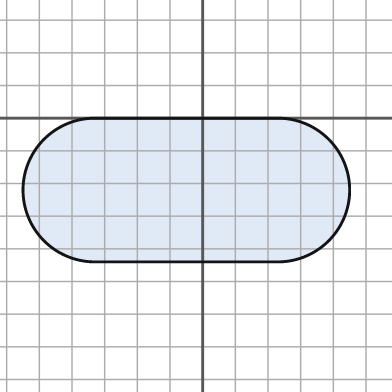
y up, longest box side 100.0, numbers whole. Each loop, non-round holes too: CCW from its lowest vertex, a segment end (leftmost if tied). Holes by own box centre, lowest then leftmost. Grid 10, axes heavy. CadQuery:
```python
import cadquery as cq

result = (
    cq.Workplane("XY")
    .moveTo(-33.0, -44.0)
    .lineTo(23.0, -44.0)
    .threePointArc((45.0, -22.0), (23.0, 0.0))
    .lineTo(-33.0, 0.0)
    .threePointArc((-55.0, -22.0), (-33.0, -44.0))
    .close()
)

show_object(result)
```